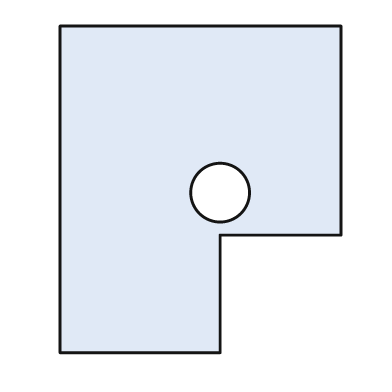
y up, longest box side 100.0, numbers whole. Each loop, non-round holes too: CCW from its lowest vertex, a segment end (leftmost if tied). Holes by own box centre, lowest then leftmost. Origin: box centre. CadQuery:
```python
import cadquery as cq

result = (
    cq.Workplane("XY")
    .moveTo(-43.0, -50.0)
    .lineTo(6.0, -50.0)
    .lineTo(6.0, -14.0)
    .lineTo(43.0, -14.0)
    .lineTo(43.0, 50.0)
    .lineTo(-43.0, 50.0)
    .close()
    .moveTo(6.0, -1.0)
    .circle(9.0)
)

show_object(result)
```